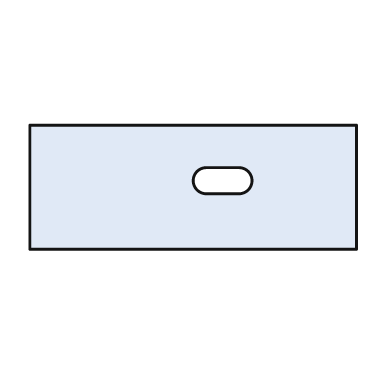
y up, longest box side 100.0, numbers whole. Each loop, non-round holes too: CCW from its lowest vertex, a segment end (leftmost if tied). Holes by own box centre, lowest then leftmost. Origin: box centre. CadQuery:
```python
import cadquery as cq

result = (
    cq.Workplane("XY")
    .moveTo(-50.0, -19.0)
    .lineTo(50.0, -19.0)
    .lineTo(50.0, 19.0)
    .lineTo(-50.0, 19.0)
    .close()
    .moveTo(4.0, -2.0)
    .lineTo(14.0, -2.0)
    .threePointArc((18.0, 2.0), (14.0, 6.0))
    .lineTo(4.0, 6.0)
    .threePointArc((0.0, 2.0), (4.0, -2.0))
    .close()
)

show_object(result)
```